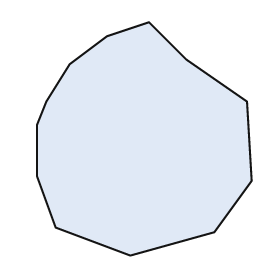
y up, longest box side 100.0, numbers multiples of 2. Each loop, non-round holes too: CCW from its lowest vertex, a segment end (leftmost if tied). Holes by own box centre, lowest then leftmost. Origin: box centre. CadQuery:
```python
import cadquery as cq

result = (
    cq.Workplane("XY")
    .moveTo(-6.0, -50.0)
    .lineTo(30.0, -40.0)
    .lineTo(46.0, -18.0)
    .lineTo(44.0, 16.0)
    .lineTo(18.0, 34.0)
    .lineTo(2.0, 50.0)
    .lineTo(-16.0, 44.0)
    .lineTo(-32.0, 32.0)
    .lineTo(-42.0, 16.0)
    .lineTo(-46.0, 6.0)
    .lineTo(-46.0, -16.0)
    .lineTo(-38.0, -38.0)
    .close()
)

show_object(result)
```